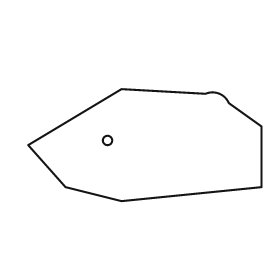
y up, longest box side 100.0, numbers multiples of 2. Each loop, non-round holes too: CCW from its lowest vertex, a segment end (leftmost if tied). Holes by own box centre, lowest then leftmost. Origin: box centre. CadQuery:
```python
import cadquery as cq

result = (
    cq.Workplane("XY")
    .moveTo(-10.0, -24.0)
    .lineTo(50.0, -18.0)
    .lineTo(50.0, 8.0)
    .lineTo(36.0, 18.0)
    .threePointArc((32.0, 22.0), (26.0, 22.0))
    .lineTo(-10.0, 24.0)
    .lineTo(-50.0, 0.0)
    .lineTo(-34.0, -18.0)
    .close()
    .moveTo(-16.0, 2.0)
    .circle(2.0)
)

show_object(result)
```